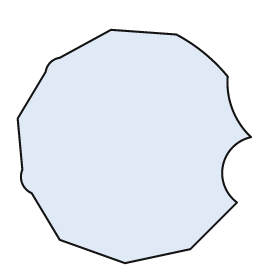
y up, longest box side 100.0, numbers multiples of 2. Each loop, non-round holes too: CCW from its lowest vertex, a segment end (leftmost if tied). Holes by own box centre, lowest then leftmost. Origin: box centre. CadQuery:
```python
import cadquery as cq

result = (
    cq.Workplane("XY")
    .moveTo(-4.0, -50.0)
    .lineTo(24.0, -44.0)
    .lineTo(44.0, -24.0)
    .threePointArc((38.0, -8.0), (50.0, 4.0))
    .threePointArc((42.0, 16.0), (40.0, 30.0))
    .threePointArc((30.0, 40.0), (18.0, 48.0))
    .lineTo(-10.0, 50.0)
    .lineTo(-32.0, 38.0)
    .threePointArc((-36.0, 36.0), (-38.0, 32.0))
    .lineTo(-50.0, 12.0)
    .lineTo(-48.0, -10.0)
    .threePointArc((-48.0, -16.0), (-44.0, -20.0))
    .lineTo(-32.0, -40.0)
    .close()
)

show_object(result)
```